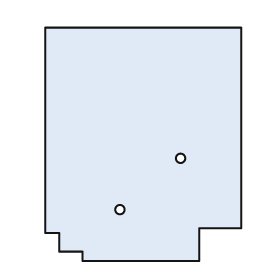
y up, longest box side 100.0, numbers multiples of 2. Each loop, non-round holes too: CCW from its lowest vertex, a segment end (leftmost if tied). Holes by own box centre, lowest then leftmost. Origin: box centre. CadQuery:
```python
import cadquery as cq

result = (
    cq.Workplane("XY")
    .moveTo(-26.0, -50.0)
    .lineTo(24.0, -50.0)
    .lineTo(24.0, -36.0)
    .lineTo(42.0, -36.0)
    .lineTo(42.0, 50.0)
    .lineTo(-42.0, 50.0)
    .lineTo(-42.0, -38.0)
    .lineTo(-36.0, -38.0)
    .lineTo(-36.0, -46.0)
    .lineTo(-26.0, -46.0)
    .close()
    .moveTo(-10.0, -28.0)
    .circle(2.0)
    .moveTo(16.0, -6.0)
    .circle(2.0)
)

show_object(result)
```